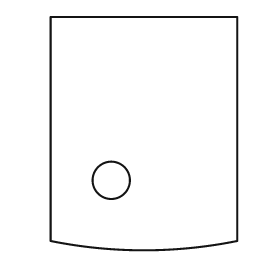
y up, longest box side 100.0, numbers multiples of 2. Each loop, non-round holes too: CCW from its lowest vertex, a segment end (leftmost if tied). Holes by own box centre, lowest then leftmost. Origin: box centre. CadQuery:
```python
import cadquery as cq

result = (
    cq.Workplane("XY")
    .moveTo(-40.0, -46.0)
    .threePointArc((0.0, -50.0), (40.0, -46.0))
    .lineTo(40.0, 50.0)
    .lineTo(-40.0, 50.0)
    .close()
    .moveTo(-14.0, -20.0)
    .circle(8.0)
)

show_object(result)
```